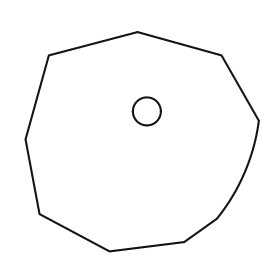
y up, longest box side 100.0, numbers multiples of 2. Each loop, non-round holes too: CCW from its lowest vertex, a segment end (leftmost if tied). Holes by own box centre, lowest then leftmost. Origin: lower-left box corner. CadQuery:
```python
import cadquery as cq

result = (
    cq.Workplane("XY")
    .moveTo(36.0, 0.0)
    .lineTo(68.0, 4.0)
    .lineTo(82.0, 14.0)
    .threePointArc((94.0, 34.0), (100.0, 56.0))
    .lineTo(84.0, 84.0)
    .lineTo(48.0, 94.0)
    .lineTo(10.0, 84.0)
    .lineTo(0.0, 48.0)
    .lineTo(6.0, 16.0)
    .close()
    .moveTo(52.0, 60.0)
    .circle(6.0)
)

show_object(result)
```